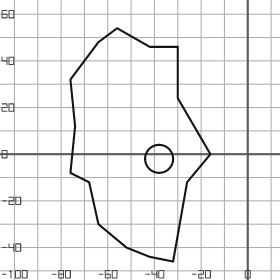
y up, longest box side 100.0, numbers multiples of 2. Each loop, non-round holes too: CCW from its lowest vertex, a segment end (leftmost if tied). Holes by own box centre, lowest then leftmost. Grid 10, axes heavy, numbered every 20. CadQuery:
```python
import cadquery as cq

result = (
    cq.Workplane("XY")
    .moveTo(-32.0, -46.0)
    .lineTo(-26.0, -12.0)
    .lineTo(-16.0, 0.0)
    .lineTo(-30.0, 24.0)
    .lineTo(-30.0, 46.0)
    .lineTo(-42.0, 46.0)
    .lineTo(-56.0, 54.0)
    .lineTo(-64.0, 48.0)
    .lineTo(-76.0, 32.0)
    .lineTo(-74.0, 12.0)
    .lineTo(-76.0, -8.0)
    .lineTo(-68.0, -12.0)
    .lineTo(-64.0, -30.0)
    .lineTo(-52.0, -40.0)
    .lineTo(-42.0, -44.0)
    .close()
    .moveTo(-38.0, -2.0)
    .circle(6.0)
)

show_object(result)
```